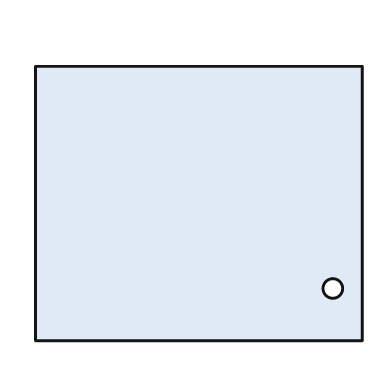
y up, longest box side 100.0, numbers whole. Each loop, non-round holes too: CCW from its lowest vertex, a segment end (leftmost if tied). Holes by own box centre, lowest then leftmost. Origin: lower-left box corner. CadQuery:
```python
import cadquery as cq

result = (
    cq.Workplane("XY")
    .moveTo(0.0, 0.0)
    .lineTo(100.0, 0.0)
    .lineTo(100.0, 84.0)
    .lineTo(0.0, 84.0)
    .close()
    .moveTo(91.0, 16.0)
    .circle(3.0)
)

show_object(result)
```